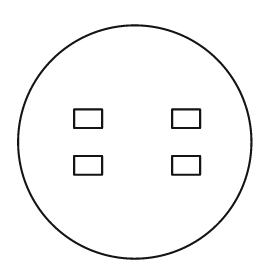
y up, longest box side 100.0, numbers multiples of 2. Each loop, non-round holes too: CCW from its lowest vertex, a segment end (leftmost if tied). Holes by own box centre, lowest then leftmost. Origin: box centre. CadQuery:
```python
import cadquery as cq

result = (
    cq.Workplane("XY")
    .moveTo(0.0, 0.0)
    .circle(50.0)
    .moveTo(-26.0, -14.0)
    .lineTo(-14.0, -14.0)
    .lineTo(-14.0, -6.0)
    .lineTo(-26.0, -6.0)
    .close()
    .moveTo(16.0, -14.0)
    .lineTo(28.0, -14.0)
    .lineTo(28.0, -6.0)
    .lineTo(16.0, -6.0)
    .close()
    .moveTo(-26.0, 6.0)
    .lineTo(-14.0, 6.0)
    .lineTo(-14.0, 14.0)
    .lineTo(-26.0, 14.0)
    .close()
    .moveTo(16.0, 6.0)
    .lineTo(28.0, 6.0)
    .lineTo(28.0, 14.0)
    .lineTo(16.0, 14.0)
    .close()
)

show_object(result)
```